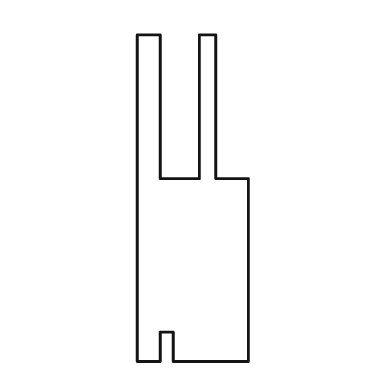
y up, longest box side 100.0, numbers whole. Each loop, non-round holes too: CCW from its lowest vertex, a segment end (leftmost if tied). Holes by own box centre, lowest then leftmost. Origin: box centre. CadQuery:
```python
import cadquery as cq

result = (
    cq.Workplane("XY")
    .moveTo(-17.0, -50.0)
    .lineTo(-10.0, -50.0)
    .lineTo(-10.0, -41.0)
    .lineTo(-6.0, -41.0)
    .lineTo(-6.0, -50.0)
    .lineTo(17.0, -50.0)
    .lineTo(17.0, 6.0)
    .lineTo(7.0, 6.0)
    .lineTo(7.0, 50.0)
    .lineTo(2.0, 50.0)
    .lineTo(2.0, 6.0)
    .lineTo(-10.0, 6.0)
    .lineTo(-10.0, 50.0)
    .lineTo(-17.0, 50.0)
    .close()
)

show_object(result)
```